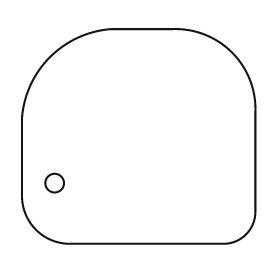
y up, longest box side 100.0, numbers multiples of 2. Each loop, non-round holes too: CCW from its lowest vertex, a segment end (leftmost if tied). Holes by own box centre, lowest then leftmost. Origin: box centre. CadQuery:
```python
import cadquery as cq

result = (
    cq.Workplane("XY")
    .moveTo(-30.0, -46.0)
    .lineTo(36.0, -46.0)
    .threePointArc((46.0, -42.0), (50.0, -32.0))
    .lineTo(50.0, 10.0)
    .threePointArc((40.0, 36.0), (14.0, 46.0))
    .lineTo(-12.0, 46.0)
    .threePointArc((-38.0, 34.0), (-50.0, 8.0))
    .lineTo(-50.0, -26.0)
    .threePointArc((-44.0, -40.0), (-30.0, -46.0))
    .close()
    .moveTo(-36.0, -20.0)
    .circle(4.0)
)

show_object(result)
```